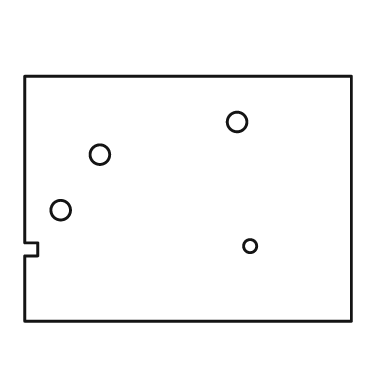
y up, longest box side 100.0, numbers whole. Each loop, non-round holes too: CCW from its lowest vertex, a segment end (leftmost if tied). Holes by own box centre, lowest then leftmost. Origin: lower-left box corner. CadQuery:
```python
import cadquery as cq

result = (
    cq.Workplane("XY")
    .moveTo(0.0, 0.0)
    .lineTo(100.0, 0.0)
    .lineTo(100.0, 75.0)
    .lineTo(0.0, 75.0)
    .lineTo(0.0, 24.0)
    .lineTo(4.0, 24.0)
    .lineTo(4.0, 20.0)
    .lineTo(0.0, 20.0)
    .close()
    .moveTo(69.0, 23.0)
    .circle(2.0)
    .moveTo(11.0, 34.0)
    .circle(3.0)
    .moveTo(23.0, 51.0)
    .circle(3.0)
    .moveTo(65.0, 61.0)
    .circle(3.0)
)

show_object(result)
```